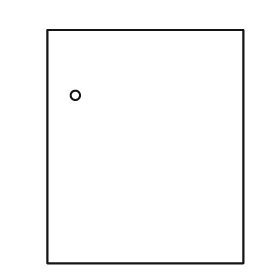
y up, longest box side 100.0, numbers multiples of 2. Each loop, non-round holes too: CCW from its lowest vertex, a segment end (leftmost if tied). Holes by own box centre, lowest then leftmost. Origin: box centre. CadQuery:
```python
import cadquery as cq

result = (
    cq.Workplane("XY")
    .moveTo(-42.0, -50.0)
    .lineTo(42.0, -50.0)
    .lineTo(42.0, 50.0)
    .lineTo(-42.0, 50.0)
    .close()
    .moveTo(-30.0, 22.0)
    .circle(2.0)
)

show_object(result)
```